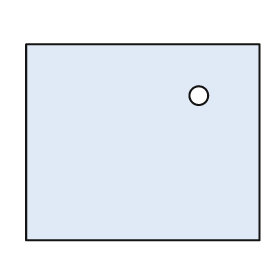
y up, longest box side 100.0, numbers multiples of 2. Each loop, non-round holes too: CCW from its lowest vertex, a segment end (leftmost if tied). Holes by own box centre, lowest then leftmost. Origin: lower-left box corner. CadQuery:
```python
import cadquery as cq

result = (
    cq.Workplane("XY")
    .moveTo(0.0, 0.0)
    .lineTo(100.0, 0.0)
    .lineTo(100.0, 84.0)
    .lineTo(0.0, 84.0)
    .close()
    .moveTo(74.0, 62.0)
    .circle(4.0)
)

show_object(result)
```